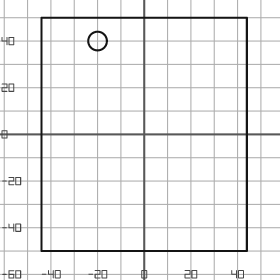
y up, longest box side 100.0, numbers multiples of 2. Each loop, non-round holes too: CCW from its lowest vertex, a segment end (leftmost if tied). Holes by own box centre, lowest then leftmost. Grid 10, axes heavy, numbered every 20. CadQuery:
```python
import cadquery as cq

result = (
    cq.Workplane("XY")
    .moveTo(-44.0, -50.0)
    .lineTo(44.0, -50.0)
    .lineTo(44.0, 50.0)
    .lineTo(-44.0, 50.0)
    .close()
    .moveTo(-20.0, 40.0)
    .circle(4.0)
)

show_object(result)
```